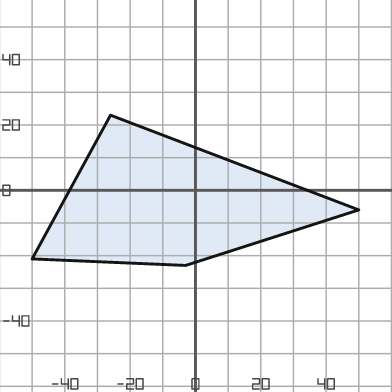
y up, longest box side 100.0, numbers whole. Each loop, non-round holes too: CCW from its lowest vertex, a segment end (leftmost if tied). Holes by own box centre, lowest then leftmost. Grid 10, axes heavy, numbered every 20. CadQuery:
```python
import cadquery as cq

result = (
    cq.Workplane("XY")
    .moveTo(-3.0, -23.0)
    .lineTo(50.0, -6.0)
    .lineTo(-26.0, 23.0)
    .lineTo(-50.0, -21.0)
    .close()
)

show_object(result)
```